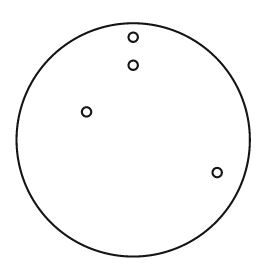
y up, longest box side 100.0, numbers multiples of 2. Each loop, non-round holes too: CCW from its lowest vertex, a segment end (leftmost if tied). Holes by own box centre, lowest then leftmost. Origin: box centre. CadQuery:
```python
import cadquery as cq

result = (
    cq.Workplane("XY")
    .moveTo(0.0, 0.0)
    .circle(50.0)
    .moveTo(36.0, -14.0)
    .circle(2.0)
    .moveTo(-20.0, 12.0)
    .circle(2.0)
    .moveTo(0.0, 32.0)
    .circle(2.0)
    .moveTo(0.0, 44.0)
    .circle(2.0)
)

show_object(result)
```